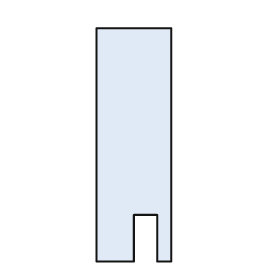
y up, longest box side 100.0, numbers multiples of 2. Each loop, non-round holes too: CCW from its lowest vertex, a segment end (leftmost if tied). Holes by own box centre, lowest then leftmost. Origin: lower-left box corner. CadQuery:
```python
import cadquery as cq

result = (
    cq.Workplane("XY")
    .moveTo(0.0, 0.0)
    .lineTo(16.0, 0.0)
    .lineTo(16.0, 20.0)
    .lineTo(26.0, 20.0)
    .lineTo(26.0, 0.0)
    .lineTo(32.0, 0.0)
    .lineTo(32.0, 100.0)
    .lineTo(0.0, 100.0)
    .close()
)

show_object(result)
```